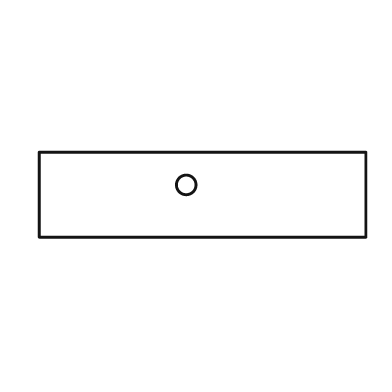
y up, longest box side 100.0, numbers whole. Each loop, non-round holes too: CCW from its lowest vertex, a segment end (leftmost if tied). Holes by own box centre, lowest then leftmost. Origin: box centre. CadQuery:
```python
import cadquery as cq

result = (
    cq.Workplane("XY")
    .moveTo(-50.0, -13.0)
    .lineTo(50.0, -13.0)
    .lineTo(50.0, 13.0)
    .lineTo(-50.0, 13.0)
    .close()
    .moveTo(-5.0, 3.0)
    .circle(3.0)
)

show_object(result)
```